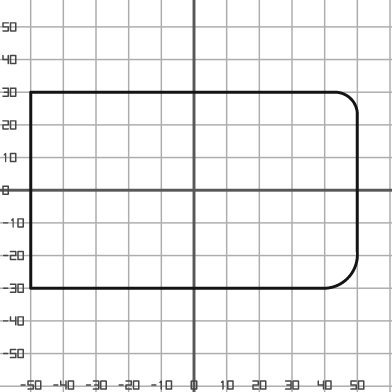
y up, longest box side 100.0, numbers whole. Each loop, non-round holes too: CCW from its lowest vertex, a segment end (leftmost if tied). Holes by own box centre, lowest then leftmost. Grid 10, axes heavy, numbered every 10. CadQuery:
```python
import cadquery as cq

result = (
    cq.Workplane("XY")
    .moveTo(-50.0, -30.0)
    .lineTo(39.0, -30.0)
    .threePointArc((47.0, -27.0), (50.0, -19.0))
    .lineTo(50.0, 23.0)
    .threePointArc((48.0, 28.0), (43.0, 30.0))
    .lineTo(-50.0, 30.0)
    .close()
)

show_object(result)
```